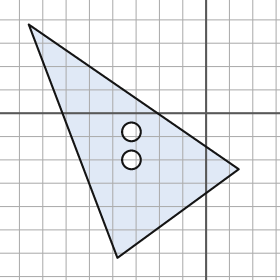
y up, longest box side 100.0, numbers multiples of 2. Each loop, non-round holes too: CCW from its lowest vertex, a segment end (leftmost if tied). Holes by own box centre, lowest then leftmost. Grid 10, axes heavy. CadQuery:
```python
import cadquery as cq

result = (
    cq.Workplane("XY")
    .moveTo(-38.0, -62.0)
    .lineTo(14.0, -24.0)
    .lineTo(-76.0, 38.0)
    .close()
    .moveTo(-32.0, -20.0)
    .circle(4.0)
    .moveTo(-32.0, -8.0)
    .circle(4.0)
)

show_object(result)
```